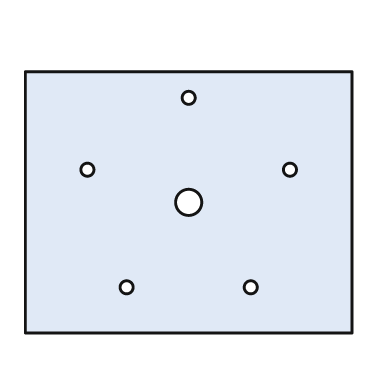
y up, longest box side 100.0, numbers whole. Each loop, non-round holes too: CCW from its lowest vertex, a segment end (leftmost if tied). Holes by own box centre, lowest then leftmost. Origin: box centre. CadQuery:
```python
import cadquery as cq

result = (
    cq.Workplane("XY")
    .moveTo(-50.0, -40.0)
    .lineTo(50.0, -40.0)
    .lineTo(50.0, 40.0)
    .lineTo(-50.0, 40.0)
    .close()
    .moveTo(-19.0, -26.0)
    .circle(2.0)
    .moveTo(19.0, -26.0)
    .circle(2.0)
    .moveTo(0.0, 0.0)
    .circle(4.0)
    .moveTo(-31.0, 10.0)
    .circle(2.0)
    .moveTo(31.0, 10.0)
    .circle(2.0)
    .moveTo(0.0, 32.0)
    .circle(2.0)
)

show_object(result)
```